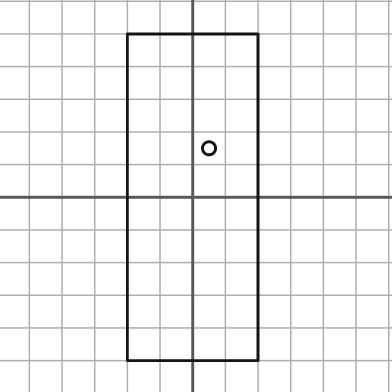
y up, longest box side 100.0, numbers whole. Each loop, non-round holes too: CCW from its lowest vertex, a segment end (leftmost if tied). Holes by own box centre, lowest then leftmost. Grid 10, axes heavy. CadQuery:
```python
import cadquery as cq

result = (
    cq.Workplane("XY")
    .moveTo(-20.0, -50.0)
    .lineTo(20.0, -50.0)
    .lineTo(20.0, 50.0)
    .lineTo(-20.0, 50.0)
    .close()
    .moveTo(5.0, 15.0)
    .circle(2.0)
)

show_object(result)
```